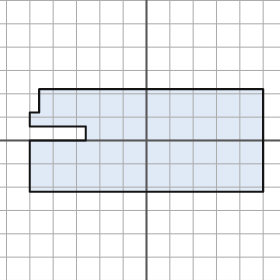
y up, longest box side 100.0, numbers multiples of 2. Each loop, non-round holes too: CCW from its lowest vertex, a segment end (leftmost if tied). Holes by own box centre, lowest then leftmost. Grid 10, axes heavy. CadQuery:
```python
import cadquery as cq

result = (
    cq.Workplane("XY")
    .moveTo(-50.0, -22.0)
    .lineTo(50.0, -22.0)
    .lineTo(50.0, 22.0)
    .lineTo(-46.0, 22.0)
    .lineTo(-46.0, 12.0)
    .lineTo(-50.0, 12.0)
    .lineTo(-50.0, 6.0)
    .lineTo(-26.0, 6.0)
    .lineTo(-26.0, 0.0)
    .lineTo(-50.0, 0.0)
    .close()
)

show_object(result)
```